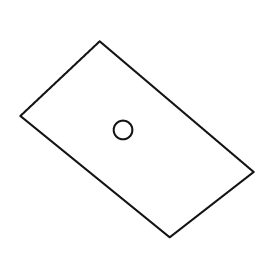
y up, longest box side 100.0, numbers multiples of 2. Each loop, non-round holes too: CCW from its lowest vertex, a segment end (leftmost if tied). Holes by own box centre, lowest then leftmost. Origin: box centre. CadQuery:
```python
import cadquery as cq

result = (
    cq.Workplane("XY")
    .moveTo(14.0, -42.0)
    .lineTo(50.0, -14.0)
    .lineTo(-16.0, 42.0)
    .lineTo(-50.0, 10.0)
    .close()
    .moveTo(-6.0, 4.0)
    .circle(4.0)
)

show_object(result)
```